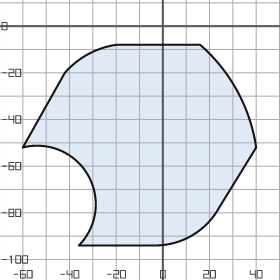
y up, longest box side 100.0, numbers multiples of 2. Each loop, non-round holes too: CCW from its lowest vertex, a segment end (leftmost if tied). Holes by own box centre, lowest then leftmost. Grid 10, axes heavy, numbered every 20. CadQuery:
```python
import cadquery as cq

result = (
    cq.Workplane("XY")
    .moveTo(-36.0, -94.0)
    .lineTo(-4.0, -94.0)
    .threePointArc((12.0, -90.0), (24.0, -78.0))
    .lineTo(40.0, -52.0)
    .threePointArc((32.0, -28.0), (16.0, -8.0))
    .lineTo(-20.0, -8.0)
    .threePointArc((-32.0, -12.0), (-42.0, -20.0))
    .lineTo(-60.0, -52.0)
    .threePointArc((-32.0, -64.0), (-36.0, -94.0))
    .close()
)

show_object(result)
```